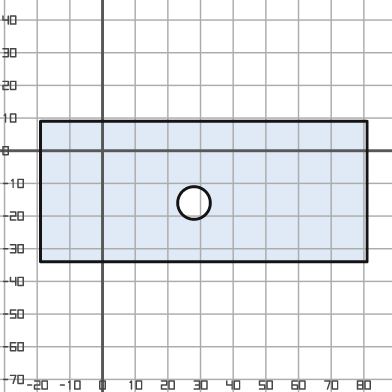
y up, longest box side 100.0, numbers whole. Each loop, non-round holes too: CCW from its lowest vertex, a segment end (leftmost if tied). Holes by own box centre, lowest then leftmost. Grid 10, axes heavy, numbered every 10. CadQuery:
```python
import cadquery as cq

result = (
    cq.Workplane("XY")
    .moveTo(-19.0, -34.0)
    .lineTo(81.0, -34.0)
    .lineTo(81.0, 9.0)
    .lineTo(-19.0, 9.0)
    .close()
    .moveTo(28.0, -16.0)
    .circle(5.0)
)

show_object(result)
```